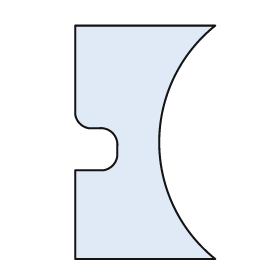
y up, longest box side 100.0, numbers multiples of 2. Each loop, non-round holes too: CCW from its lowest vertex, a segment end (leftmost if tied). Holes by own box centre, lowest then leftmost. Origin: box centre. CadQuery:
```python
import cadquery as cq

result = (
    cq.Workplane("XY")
    .moveTo(-30.0, -50.0)
    .lineTo(30.0, -50.0)
    .threePointArc((6.0, 0.0), (30.0, 50.0))
    .lineTo(-30.0, 50.0)
    .lineTo(-30.0, 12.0)
    .threePointArc((-28.0, 8.0), (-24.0, 6.0))
    .lineTo(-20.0, 6.0)
    .threePointArc((-14.0, 4.0), (-12.0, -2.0))
    .lineTo(-12.0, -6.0)
    .threePointArc((-14.0, -10.0), (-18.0, -12.0))
    .lineTo(-30.0, -12.0)
    .close()
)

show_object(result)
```